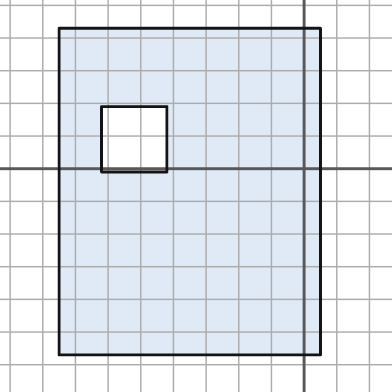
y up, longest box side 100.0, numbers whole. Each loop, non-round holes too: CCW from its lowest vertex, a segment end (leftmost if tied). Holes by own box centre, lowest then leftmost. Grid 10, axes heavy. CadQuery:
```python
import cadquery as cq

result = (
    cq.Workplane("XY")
    .moveTo(-75.0, -57.0)
    .lineTo(5.0, -57.0)
    .lineTo(5.0, 43.0)
    .lineTo(-75.0, 43.0)
    .close()
    .moveTo(-62.0, -1.0)
    .lineTo(-42.0, -1.0)
    .lineTo(-42.0, 19.0)
    .lineTo(-62.0, 19.0)
    .close()
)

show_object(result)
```